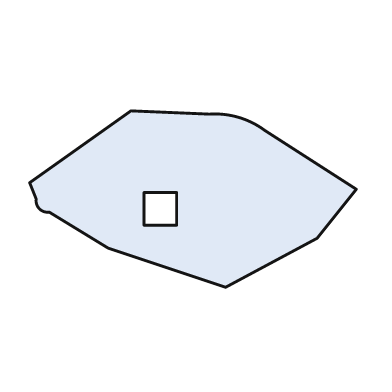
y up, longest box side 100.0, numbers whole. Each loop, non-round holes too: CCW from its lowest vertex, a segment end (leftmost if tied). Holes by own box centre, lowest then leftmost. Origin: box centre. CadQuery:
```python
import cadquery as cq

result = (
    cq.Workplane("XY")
    .moveTo(10.0, -27.0)
    .lineTo(38.0, -12.0)
    .lineTo(50.0, 3.0)
    .lineTo(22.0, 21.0)
    .threePointArc((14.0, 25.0), (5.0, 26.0))
    .lineTo(-19.0, 27.0)
    .lineTo(-50.0, 5.0)
    .lineTo(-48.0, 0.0)
    .threePointArc((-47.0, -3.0), (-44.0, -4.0))
    .lineTo(-26.0, -15.0)
    .close()
    .moveTo(-15.0, -8.0)
    .lineTo(-5.0, -8.0)
    .lineTo(-5.0, 2.0)
    .lineTo(-15.0, 2.0)
    .close()
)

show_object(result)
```